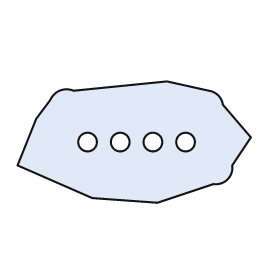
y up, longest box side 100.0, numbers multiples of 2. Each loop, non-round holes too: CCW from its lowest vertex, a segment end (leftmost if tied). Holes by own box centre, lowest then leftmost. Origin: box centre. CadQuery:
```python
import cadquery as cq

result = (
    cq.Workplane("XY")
    .moveTo(10.0, -26.0)
    .lineTo(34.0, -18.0)
    .threePointArc((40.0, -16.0), (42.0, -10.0))
    .lineTo(50.0, 2.0)
    .lineTo(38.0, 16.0)
    .threePointArc((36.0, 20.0), (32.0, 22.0))
    .lineTo(14.0, 26.0)
    .lineTo(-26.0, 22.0)
    .threePointArc((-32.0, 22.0), (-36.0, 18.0))
    .lineTo(-42.0, 10.0)
    .lineTo(-50.0, -10.0)
    .lineTo(-18.0, -24.0)
    .close()
    .moveTo(-20.0, 0.0)
    .circle(4.0)
    .moveTo(-6.0, 0.0)
    .circle(4.0)
    .moveTo(8.0, 0.0)
    .circle(4.0)
    .moveTo(22.0, 0.0)
    .circle(4.0)
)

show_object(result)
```